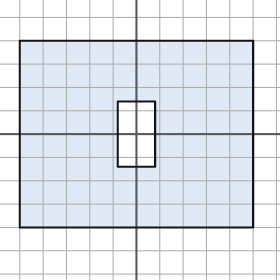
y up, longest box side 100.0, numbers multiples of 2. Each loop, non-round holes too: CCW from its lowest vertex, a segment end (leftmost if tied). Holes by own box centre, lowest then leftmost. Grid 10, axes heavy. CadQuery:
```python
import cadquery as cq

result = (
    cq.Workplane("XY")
    .moveTo(-50.0, -40.0)
    .lineTo(50.0, -40.0)
    .lineTo(50.0, 40.0)
    .lineTo(-50.0, 40.0)
    .close()
    .moveTo(-8.0, -14.0)
    .lineTo(8.0, -14.0)
    .lineTo(8.0, 14.0)
    .lineTo(-8.0, 14.0)
    .close()
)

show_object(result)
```